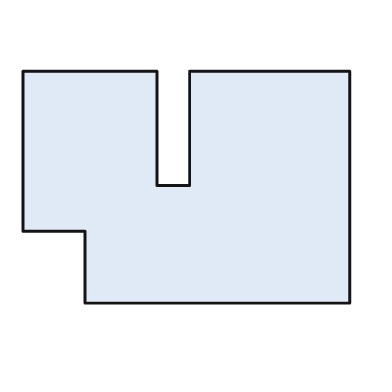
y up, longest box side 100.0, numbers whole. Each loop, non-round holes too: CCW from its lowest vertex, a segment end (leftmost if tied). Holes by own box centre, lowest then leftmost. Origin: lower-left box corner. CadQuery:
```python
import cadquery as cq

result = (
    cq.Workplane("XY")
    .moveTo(19.0, 0.0)
    .lineTo(100.0, 0.0)
    .lineTo(100.0, 71.0)
    .lineTo(51.0, 71.0)
    .lineTo(51.0, 36.0)
    .lineTo(41.0, 36.0)
    .lineTo(41.0, 71.0)
    .lineTo(0.0, 71.0)
    .lineTo(0.0, 22.0)
    .lineTo(19.0, 22.0)
    .close()
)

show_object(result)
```